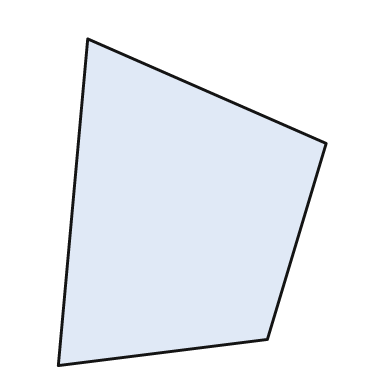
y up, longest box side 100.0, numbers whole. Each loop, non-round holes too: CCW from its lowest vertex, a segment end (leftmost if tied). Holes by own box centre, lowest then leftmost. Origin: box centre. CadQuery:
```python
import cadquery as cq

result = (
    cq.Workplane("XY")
    .moveTo(-41.0, -50.0)
    .lineTo(23.0, -42.0)
    .lineTo(41.0, 18.0)
    .lineTo(-32.0, 50.0)
    .close()
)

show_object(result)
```